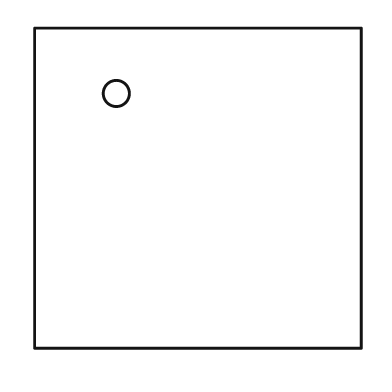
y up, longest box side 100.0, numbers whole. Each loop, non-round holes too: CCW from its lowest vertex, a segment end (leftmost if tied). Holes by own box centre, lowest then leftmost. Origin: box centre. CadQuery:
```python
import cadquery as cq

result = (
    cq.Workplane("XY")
    .moveTo(-50.0, -49.0)
    .lineTo(50.0, -49.0)
    .lineTo(50.0, 49.0)
    .lineTo(-50.0, 49.0)
    .close()
    .moveTo(-25.0, 29.0)
    .circle(4.0)
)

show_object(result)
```